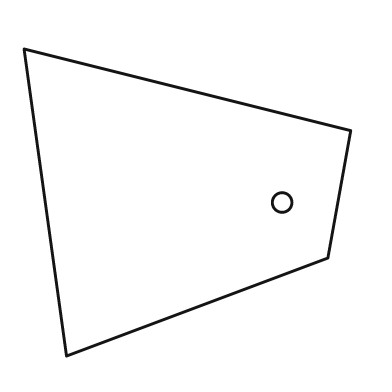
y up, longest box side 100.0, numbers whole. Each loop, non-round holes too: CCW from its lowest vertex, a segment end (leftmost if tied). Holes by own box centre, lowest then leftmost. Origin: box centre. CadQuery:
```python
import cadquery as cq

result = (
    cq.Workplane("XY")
    .moveTo(-37.0, -47.0)
    .lineTo(43.0, -17.0)
    .lineTo(50.0, 22.0)
    .lineTo(-50.0, 47.0)
    .close()
    .moveTo(29.0, 0.0)
    .circle(3.0)
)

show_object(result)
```